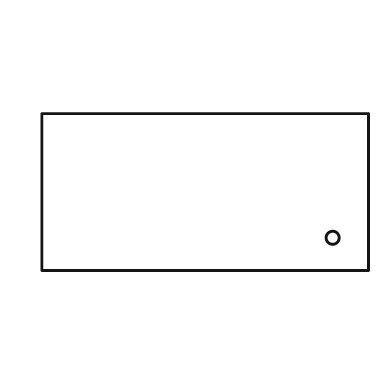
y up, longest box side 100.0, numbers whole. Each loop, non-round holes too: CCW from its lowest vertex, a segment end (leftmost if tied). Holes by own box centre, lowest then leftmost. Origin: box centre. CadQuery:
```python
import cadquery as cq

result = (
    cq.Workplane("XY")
    .moveTo(-50.0, -24.0)
    .lineTo(50.0, -24.0)
    .lineTo(50.0, 24.0)
    .lineTo(-50.0, 24.0)
    .close()
    .moveTo(39.0, -14.0)
    .circle(2.0)
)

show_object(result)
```